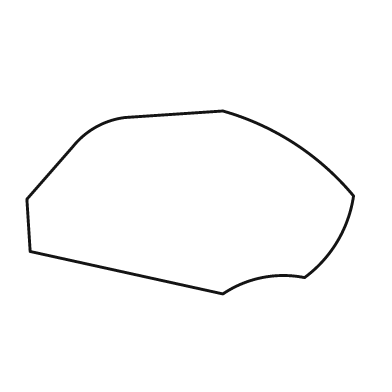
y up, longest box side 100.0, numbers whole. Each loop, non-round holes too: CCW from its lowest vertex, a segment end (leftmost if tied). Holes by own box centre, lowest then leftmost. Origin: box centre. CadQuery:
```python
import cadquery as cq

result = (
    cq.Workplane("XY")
    .moveTo(10.0, -28.0)
    .threePointArc((22.0, -23.0), (35.0, -23.0))
    .threePointArc((45.0, -12.0), (50.0, 2.0))
    .threePointArc((32.0, 18.0), (10.0, 28.0))
    .lineTo(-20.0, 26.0)
    .threePointArc((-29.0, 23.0), (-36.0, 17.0))
    .lineTo(-50.0, 1.0)
    .lineTo(-49.0, -15.0)
    .close()
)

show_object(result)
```